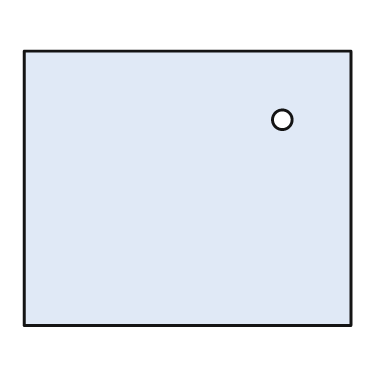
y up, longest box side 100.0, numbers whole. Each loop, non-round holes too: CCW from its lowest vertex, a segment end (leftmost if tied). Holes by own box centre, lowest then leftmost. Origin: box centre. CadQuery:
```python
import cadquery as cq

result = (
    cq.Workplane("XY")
    .moveTo(-50.0, -42.0)
    .lineTo(50.0, -42.0)
    .lineTo(50.0, 42.0)
    .lineTo(-50.0, 42.0)
    .close()
    .moveTo(29.0, 21.0)
    .circle(3.0)
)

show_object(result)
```